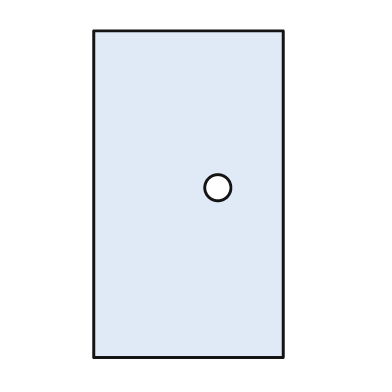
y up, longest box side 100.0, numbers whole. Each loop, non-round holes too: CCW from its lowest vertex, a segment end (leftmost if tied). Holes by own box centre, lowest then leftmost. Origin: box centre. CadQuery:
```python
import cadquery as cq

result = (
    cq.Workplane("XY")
    .moveTo(-29.0, -50.0)
    .lineTo(29.0, -50.0)
    .lineTo(29.0, 50.0)
    .lineTo(-29.0, 50.0)
    .close()
    .moveTo(9.0, 2.0)
    .circle(4.0)
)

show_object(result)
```